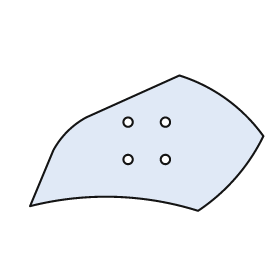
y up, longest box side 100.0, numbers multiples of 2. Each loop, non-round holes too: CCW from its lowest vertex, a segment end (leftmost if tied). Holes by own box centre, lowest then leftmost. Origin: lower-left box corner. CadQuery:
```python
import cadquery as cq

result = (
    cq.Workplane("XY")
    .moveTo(72.0, 0.0)
    .threePointArc((88.0, 14.0), (100.0, 32.0))
    .threePointArc((84.0, 48.0), (64.0, 58.0))
    .lineTo(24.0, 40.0)
    .threePointArc((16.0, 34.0), (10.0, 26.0))
    .lineTo(0.0, 2.0)
    .threePointArc((36.0, 6.0), (72.0, 0.0))
    .close()
    .moveTo(42.0, 22.0)
    .circle(2.0)
    .moveTo(58.0, 22.0)
    .circle(2.0)
    .moveTo(42.0, 38.0)
    .circle(2.0)
    .moveTo(58.0, 38.0)
    .circle(2.0)
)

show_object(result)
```